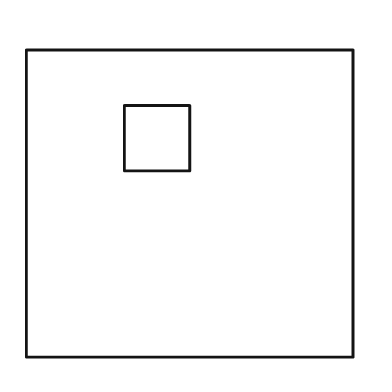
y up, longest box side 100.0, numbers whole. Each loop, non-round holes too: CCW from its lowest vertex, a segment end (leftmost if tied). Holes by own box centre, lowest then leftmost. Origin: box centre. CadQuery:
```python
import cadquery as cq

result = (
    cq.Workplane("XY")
    .moveTo(-50.0, -47.0)
    .lineTo(50.0, -47.0)
    .lineTo(50.0, 47.0)
    .lineTo(-50.0, 47.0)
    .close()
    .moveTo(-20.0, 10.0)
    .lineTo(0.0, 10.0)
    .lineTo(0.0, 30.0)
    .lineTo(-20.0, 30.0)
    .close()
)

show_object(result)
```